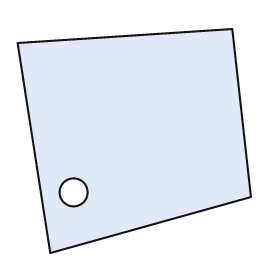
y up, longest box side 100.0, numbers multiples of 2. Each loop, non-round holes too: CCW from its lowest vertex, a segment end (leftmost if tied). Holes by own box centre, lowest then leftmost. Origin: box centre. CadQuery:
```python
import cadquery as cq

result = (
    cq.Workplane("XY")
    .moveTo(-36.0, -48.0)
    .lineTo(50.0, -24.0)
    .lineTo(42.0, 48.0)
    .lineTo(-50.0, 42.0)
    .close()
    .moveTo(-26.0, -22.0)
    .circle(6.0)
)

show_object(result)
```